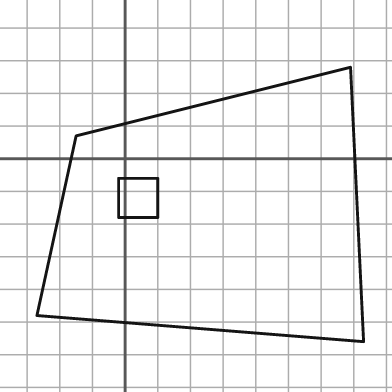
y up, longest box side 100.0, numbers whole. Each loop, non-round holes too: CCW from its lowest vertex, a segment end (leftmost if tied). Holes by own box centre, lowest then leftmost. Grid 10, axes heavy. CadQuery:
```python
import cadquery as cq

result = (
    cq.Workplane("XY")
    .moveTo(73.0, -56.0)
    .lineTo(69.0, 28.0)
    .lineTo(-15.0, 7.0)
    .lineTo(-27.0, -48.0)
    .close()
    .moveTo(-2.0, -18.0)
    .lineTo(10.0, -18.0)
    .lineTo(10.0, -6.0)
    .lineTo(-2.0, -6.0)
    .close()
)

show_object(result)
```